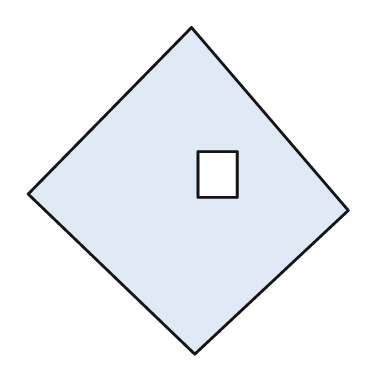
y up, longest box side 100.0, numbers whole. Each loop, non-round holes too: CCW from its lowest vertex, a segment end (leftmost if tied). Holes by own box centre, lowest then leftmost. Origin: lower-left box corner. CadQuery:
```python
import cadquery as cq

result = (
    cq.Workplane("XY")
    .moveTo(51.0, 0.0)
    .lineTo(98.0, 44.0)
    .lineTo(50.0, 100.0)
    .lineTo(0.0, 49.0)
    .close()
    .moveTo(52.0, 48.0)
    .lineTo(64.0, 48.0)
    .lineTo(64.0, 62.0)
    .lineTo(52.0, 62.0)
    .close()
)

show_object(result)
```